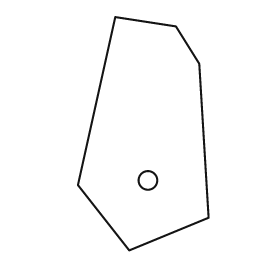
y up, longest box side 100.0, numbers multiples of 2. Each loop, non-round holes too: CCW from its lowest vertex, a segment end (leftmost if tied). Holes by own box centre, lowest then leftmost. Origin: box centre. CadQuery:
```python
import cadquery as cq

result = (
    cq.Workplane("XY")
    .moveTo(-6.0, -50.0)
    .lineTo(28.0, -36.0)
    .lineTo(24.0, 30.0)
    .lineTo(14.0, 46.0)
    .lineTo(-12.0, 50.0)
    .lineTo(-28.0, -22.0)
    .close()
    .moveTo(2.0, -20.0)
    .circle(4.0)
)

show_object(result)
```